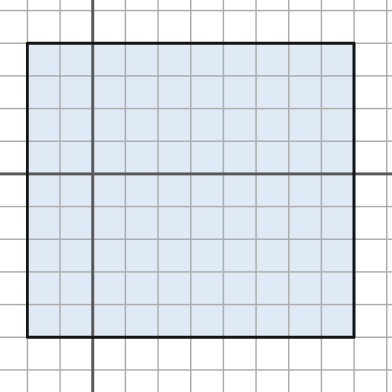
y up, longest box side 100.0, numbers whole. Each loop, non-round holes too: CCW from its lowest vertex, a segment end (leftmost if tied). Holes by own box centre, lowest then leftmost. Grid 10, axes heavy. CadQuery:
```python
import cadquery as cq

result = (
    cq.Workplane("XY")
    .moveTo(-20.0, -50.0)
    .lineTo(80.0, -50.0)
    .lineTo(80.0, 40.0)
    .lineTo(-20.0, 40.0)
    .close()
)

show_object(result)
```